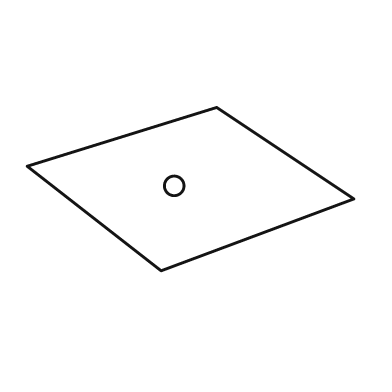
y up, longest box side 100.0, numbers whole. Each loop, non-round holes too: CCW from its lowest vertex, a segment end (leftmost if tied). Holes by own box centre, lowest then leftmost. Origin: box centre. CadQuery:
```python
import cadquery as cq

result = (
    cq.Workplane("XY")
    .moveTo(-9.0, -25.0)
    .lineTo(50.0, -3.0)
    .lineTo(8.0, 25.0)
    .lineTo(-50.0, 7.0)
    .close()
    .moveTo(-5.0, 1.0)
    .circle(3.0)
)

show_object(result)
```